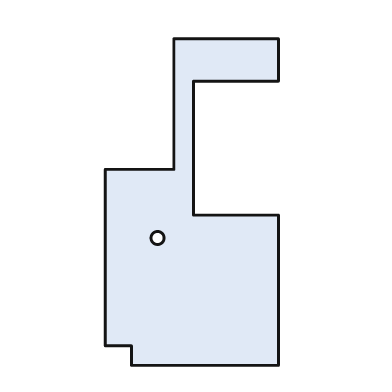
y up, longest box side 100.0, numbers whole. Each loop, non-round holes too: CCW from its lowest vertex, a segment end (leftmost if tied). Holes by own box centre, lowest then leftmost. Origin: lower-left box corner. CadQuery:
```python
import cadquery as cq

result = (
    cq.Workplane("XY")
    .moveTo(8.0, 0.0)
    .lineTo(53.0, 0.0)
    .lineTo(53.0, 46.0)
    .lineTo(27.0, 46.0)
    .lineTo(27.0, 87.0)
    .lineTo(53.0, 87.0)
    .lineTo(53.0, 100.0)
    .lineTo(21.0, 100.0)
    .lineTo(21.0, 60.0)
    .lineTo(0.0, 60.0)
    .lineTo(0.0, 6.0)
    .lineTo(8.0, 6.0)
    .close()
    .moveTo(16.0, 39.0)
    .circle(2.0)
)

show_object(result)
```